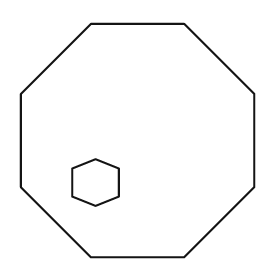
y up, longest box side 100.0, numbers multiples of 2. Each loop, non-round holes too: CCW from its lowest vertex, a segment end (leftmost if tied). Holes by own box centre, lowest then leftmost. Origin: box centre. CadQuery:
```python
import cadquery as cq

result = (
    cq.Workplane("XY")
    .moveTo(-20.0, -50.0)
    .lineTo(20.0, -50.0)
    .lineTo(50.0, -20.0)
    .lineTo(50.0, 20.0)
    .lineTo(20.0, 50.0)
    .lineTo(-20.0, 50.0)
    .lineTo(-50.0, 20.0)
    .lineTo(-50.0, -20.0)
    .close()
    .moveTo(-18.0, -28.0)
    .lineTo(-8.0, -24.0)
    .lineTo(-8.0, -12.0)
    .lineTo(-18.0, -8.0)
    .lineTo(-28.0, -12.0)
    .lineTo(-28.0, -24.0)
    .close()
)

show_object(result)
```